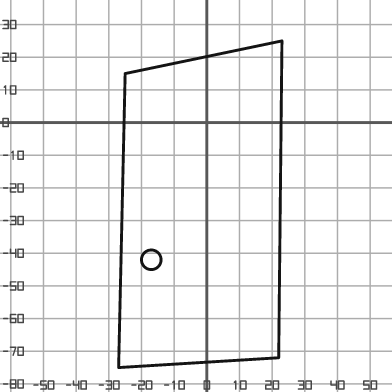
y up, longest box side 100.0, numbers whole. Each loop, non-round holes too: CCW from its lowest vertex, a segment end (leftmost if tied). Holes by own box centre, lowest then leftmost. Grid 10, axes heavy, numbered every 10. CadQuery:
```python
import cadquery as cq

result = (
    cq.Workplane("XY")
    .moveTo(-27.0, -75.0)
    .lineTo(22.0, -72.0)
    .lineTo(23.0, 25.0)
    .lineTo(-25.0, 15.0)
    .close()
    .moveTo(-17.0, -42.0)
    .circle(3.0)
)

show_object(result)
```